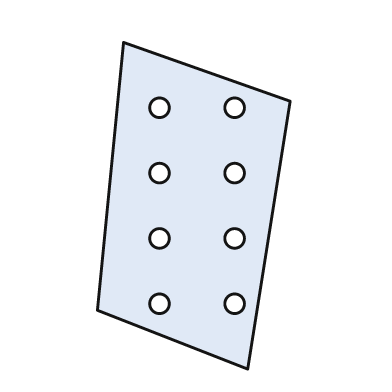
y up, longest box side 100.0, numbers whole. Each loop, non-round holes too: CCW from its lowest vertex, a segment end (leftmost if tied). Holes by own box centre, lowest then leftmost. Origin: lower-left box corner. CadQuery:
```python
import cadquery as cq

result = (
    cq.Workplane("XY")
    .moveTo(46.0, 0.0)
    .lineTo(59.0, 82.0)
    .lineTo(8.0, 100.0)
    .lineTo(0.0, 18.0)
    .close()
    .moveTo(19.0, 20.0)
    .circle(3.0)
    .moveTo(42.0, 20.0)
    .circle(3.0)
    .moveTo(19.0, 40.0)
    .circle(3.0)
    .moveTo(42.0, 40.0)
    .circle(3.0)
    .moveTo(19.0, 60.0)
    .circle(3.0)
    .moveTo(42.0, 60.0)
    .circle(3.0)
    .moveTo(19.0, 80.0)
    .circle(3.0)
    .moveTo(42.0, 80.0)
    .circle(3.0)
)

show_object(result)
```